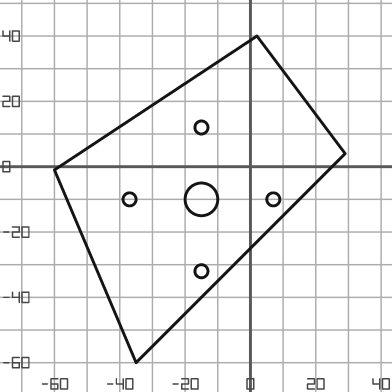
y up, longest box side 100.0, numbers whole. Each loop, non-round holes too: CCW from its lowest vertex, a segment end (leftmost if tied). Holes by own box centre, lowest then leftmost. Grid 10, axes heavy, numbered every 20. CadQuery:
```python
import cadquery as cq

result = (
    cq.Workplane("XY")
    .moveTo(-35.0, -60.0)
    .lineTo(29.0, 4.0)
    .lineTo(2.0, 40.0)
    .lineTo(-60.0, -1.0)
    .close()
    .moveTo(-15.0, -32.0)
    .circle(2.0)
    .moveTo(-37.0, -10.0)
    .circle(2.0)
    .moveTo(-15.0, -10.0)
    .circle(5.0)
    .moveTo(7.0, -10.0)
    .circle(2.0)
    .moveTo(-15.0, 12.0)
    .circle(2.0)
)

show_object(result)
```